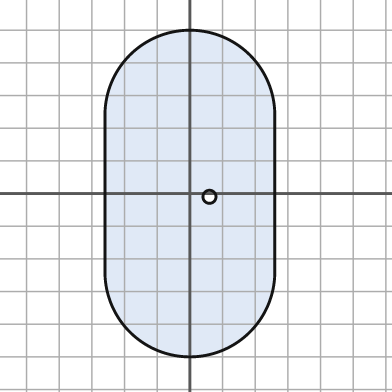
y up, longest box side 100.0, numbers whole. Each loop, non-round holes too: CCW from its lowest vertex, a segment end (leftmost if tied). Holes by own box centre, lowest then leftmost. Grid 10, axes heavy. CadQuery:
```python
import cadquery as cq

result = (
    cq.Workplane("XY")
    .moveTo(-26.0, -24.0)
    .threePointArc((0.0, -50.0), (26.0, -24.0))
    .lineTo(26.0, 24.0)
    .threePointArc((0.0, 50.0), (-26.0, 24.0))
    .close()
    .moveTo(6.0, -1.0)
    .circle(2.0)
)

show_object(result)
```